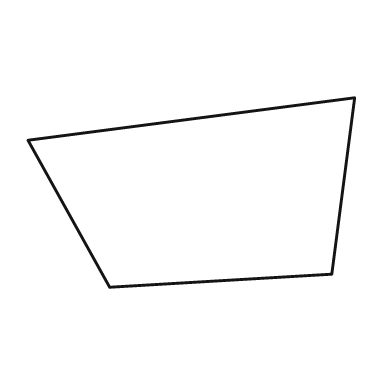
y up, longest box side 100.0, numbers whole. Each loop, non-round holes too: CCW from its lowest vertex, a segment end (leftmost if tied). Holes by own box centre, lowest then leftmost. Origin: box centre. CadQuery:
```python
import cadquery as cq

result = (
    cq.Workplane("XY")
    .moveTo(-25.0, -29.0)
    .lineTo(43.0, -25.0)
    .lineTo(50.0, 29.0)
    .lineTo(-50.0, 16.0)
    .close()
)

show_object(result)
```